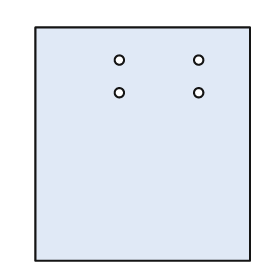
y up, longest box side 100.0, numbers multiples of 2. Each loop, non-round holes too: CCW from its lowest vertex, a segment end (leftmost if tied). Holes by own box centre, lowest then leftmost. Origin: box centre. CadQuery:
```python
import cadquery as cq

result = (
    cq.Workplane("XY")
    .moveTo(-46.0, -50.0)
    .lineTo(46.0, -50.0)
    .lineTo(46.0, 50.0)
    .lineTo(-46.0, 50.0)
    .close()
    .moveTo(-10.0, 22.0)
    .circle(2.0)
    .moveTo(24.0, 22.0)
    .circle(2.0)
    .moveTo(-10.0, 36.0)
    .circle(2.0)
    .moveTo(24.0, 36.0)
    .circle(2.0)
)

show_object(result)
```